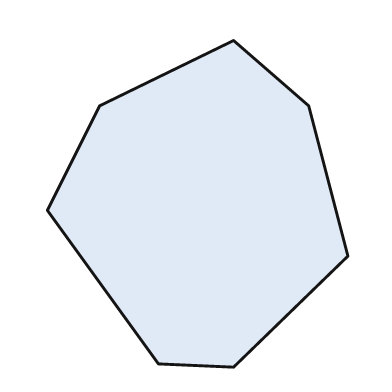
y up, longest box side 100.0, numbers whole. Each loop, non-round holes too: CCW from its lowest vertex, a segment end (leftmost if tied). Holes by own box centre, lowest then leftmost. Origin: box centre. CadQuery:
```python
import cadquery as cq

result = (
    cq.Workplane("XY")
    .moveTo(11.0, -50.0)
    .lineTo(46.0, -16.0)
    .lineTo(34.0, 30.0)
    .lineTo(11.0, 50.0)
    .lineTo(-30.0, 30.0)
    .lineTo(-46.0, -2.0)
    .lineTo(-12.0, -49.0)
    .close()
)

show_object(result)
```